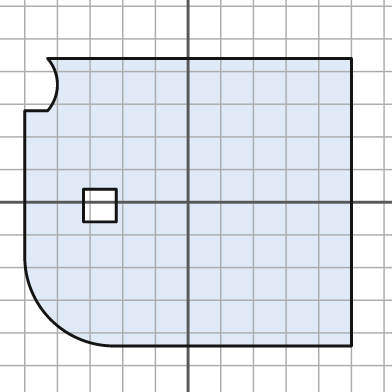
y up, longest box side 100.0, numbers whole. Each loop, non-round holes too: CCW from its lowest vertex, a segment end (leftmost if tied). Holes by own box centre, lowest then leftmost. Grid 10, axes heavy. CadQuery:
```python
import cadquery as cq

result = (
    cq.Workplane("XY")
    .moveTo(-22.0, -44.0)
    .lineTo(50.0, -44.0)
    .lineTo(50.0, 44.0)
    .lineTo(-43.0, 44.0)
    .threePointArc((-40.0, 36.0), (-43.0, 28.0))
    .lineTo(-50.0, 28.0)
    .lineTo(-50.0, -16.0)
    .threePointArc((-42.0, -36.0), (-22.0, -44.0))
    .close()
    .moveTo(-32.0, -6.0)
    .lineTo(-22.0, -6.0)
    .lineTo(-22.0, 4.0)
    .lineTo(-32.0, 4.0)
    .close()
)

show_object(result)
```